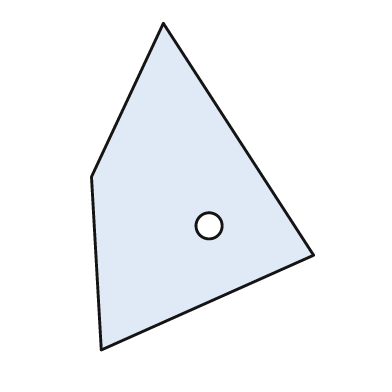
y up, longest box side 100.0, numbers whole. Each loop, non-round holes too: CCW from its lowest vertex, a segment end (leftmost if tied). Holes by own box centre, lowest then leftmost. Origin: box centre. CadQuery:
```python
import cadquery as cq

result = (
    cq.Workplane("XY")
    .moveTo(-31.0, -50.0)
    .lineTo(34.0, -21.0)
    .lineTo(-12.0, 50.0)
    .lineTo(-34.0, 3.0)
    .close()
    .moveTo(2.0, -12.0)
    .circle(4.0)
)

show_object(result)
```